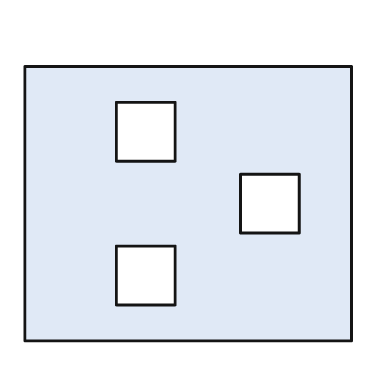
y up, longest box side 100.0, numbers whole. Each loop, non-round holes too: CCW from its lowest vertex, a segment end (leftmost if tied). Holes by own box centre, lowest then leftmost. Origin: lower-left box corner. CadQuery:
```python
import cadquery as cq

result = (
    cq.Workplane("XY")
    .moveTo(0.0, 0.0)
    .lineTo(100.0, 0.0)
    .lineTo(100.0, 84.0)
    .lineTo(0.0, 84.0)
    .close()
    .moveTo(28.0, 11.0)
    .lineTo(46.0, 11.0)
    .lineTo(46.0, 29.0)
    .lineTo(28.0, 29.0)
    .close()
    .moveTo(66.0, 33.0)
    .lineTo(84.0, 33.0)
    .lineTo(84.0, 51.0)
    .lineTo(66.0, 51.0)
    .close()
    .moveTo(28.0, 55.0)
    .lineTo(46.0, 55.0)
    .lineTo(46.0, 73.0)
    .lineTo(28.0, 73.0)
    .close()
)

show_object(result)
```